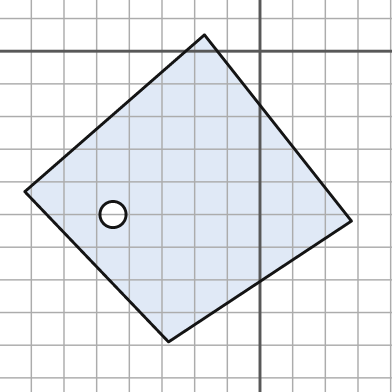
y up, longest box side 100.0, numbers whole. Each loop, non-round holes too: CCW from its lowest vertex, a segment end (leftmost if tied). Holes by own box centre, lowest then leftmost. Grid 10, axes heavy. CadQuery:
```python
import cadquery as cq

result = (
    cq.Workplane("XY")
    .moveTo(-28.0, -89.0)
    .lineTo(28.0, -52.0)
    .lineTo(-17.0, 5.0)
    .lineTo(-72.0, -43.0)
    .close()
    .moveTo(-45.0, -50.0)
    .circle(4.0)
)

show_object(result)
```